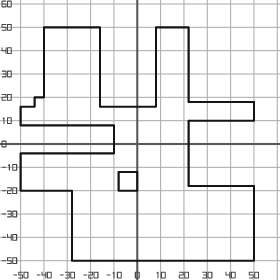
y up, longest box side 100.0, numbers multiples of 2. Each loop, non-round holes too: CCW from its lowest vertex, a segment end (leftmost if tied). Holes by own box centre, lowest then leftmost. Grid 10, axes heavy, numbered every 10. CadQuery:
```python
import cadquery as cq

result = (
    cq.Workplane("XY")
    .moveTo(-28.0, -50.0)
    .lineTo(50.0, -50.0)
    .lineTo(50.0, -18.0)
    .lineTo(22.0, -18.0)
    .lineTo(22.0, 10.0)
    .lineTo(50.0, 10.0)
    .lineTo(50.0, 18.0)
    .lineTo(22.0, 18.0)
    .lineTo(22.0, 50.0)
    .lineTo(8.0, 50.0)
    .lineTo(8.0, 16.0)
    .lineTo(-16.0, 16.0)
    .lineTo(-16.0, 50.0)
    .lineTo(-40.0, 50.0)
    .lineTo(-40.0, 20.0)
    .lineTo(-44.0, 20.0)
    .lineTo(-44.0, 16.0)
    .lineTo(-50.0, 16.0)
    .lineTo(-50.0, 8.0)
    .lineTo(-10.0, 8.0)
    .lineTo(-10.0, -4.0)
    .lineTo(-50.0, -4.0)
    .lineTo(-50.0, -20.0)
    .lineTo(-28.0, -20.0)
    .close()
    .moveTo(-8.0, -20.0)
    .lineTo(0.0, -20.0)
    .lineTo(0.0, -12.0)
    .lineTo(-8.0, -12.0)
    .close()
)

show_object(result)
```